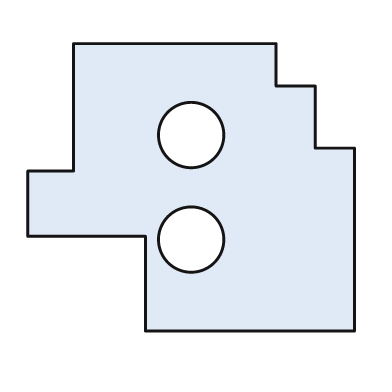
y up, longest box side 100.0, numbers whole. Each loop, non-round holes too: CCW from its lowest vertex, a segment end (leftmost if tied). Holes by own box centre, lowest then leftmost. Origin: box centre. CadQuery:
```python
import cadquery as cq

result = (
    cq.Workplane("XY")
    .moveTo(-14.0, -44.0)
    .lineTo(50.0, -44.0)
    .lineTo(50.0, 12.0)
    .lineTo(38.0, 12.0)
    .lineTo(38.0, 31.0)
    .lineTo(26.0, 31.0)
    .lineTo(26.0, 44.0)
    .lineTo(-36.0, 44.0)
    .lineTo(-36.0, 5.0)
    .lineTo(-50.0, 5.0)
    .lineTo(-50.0, -15.0)
    .lineTo(-14.0, -15.0)
    .close()
    .moveTo(0.0, -16.0)
    .circle(10.0)
    .moveTo(0.0, 16.0)
    .circle(10.0)
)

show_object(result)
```